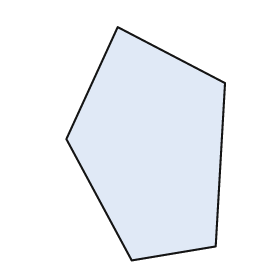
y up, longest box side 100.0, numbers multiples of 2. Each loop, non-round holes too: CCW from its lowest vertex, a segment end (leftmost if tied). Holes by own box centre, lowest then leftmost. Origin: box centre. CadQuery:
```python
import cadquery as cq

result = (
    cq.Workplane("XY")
    .moveTo(-6.0, -50.0)
    .lineTo(30.0, -44.0)
    .lineTo(34.0, 26.0)
    .lineTo(-12.0, 50.0)
    .lineTo(-34.0, 2.0)
    .close()
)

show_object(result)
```